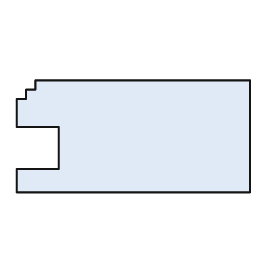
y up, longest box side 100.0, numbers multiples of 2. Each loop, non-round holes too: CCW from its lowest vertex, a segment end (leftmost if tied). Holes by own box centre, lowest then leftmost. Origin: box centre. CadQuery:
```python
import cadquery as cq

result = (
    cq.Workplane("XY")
    .moveTo(-50.0, -24.0)
    .lineTo(50.0, -24.0)
    .lineTo(50.0, 24.0)
    .lineTo(-42.0, 24.0)
    .lineTo(-42.0, 20.0)
    .lineTo(-46.0, 20.0)
    .lineTo(-46.0, 16.0)
    .lineTo(-50.0, 16.0)
    .lineTo(-50.0, 4.0)
    .lineTo(-32.0, 4.0)
    .lineTo(-32.0, -14.0)
    .lineTo(-50.0, -14.0)
    .close()
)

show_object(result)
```